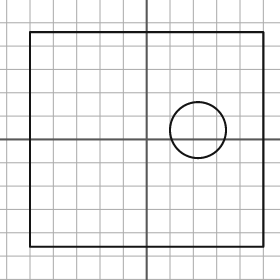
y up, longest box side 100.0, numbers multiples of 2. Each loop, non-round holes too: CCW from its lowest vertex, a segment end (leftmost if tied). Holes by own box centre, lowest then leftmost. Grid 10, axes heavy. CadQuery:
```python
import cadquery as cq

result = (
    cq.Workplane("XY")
    .moveTo(-50.0, -46.0)
    .lineTo(50.0, -46.0)
    .lineTo(50.0, 46.0)
    .lineTo(-50.0, 46.0)
    .close()
    .moveTo(22.0, 4.0)
    .circle(12.0)
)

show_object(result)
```